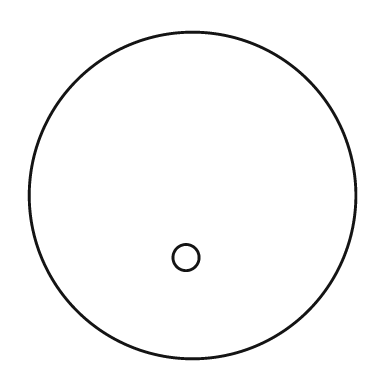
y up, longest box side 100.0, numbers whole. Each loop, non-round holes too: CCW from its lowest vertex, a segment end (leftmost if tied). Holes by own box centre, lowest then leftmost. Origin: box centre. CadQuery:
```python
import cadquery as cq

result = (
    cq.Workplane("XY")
    .moveTo(0.0, 0.0)
    .circle(50.0)
    .moveTo(-2.0, -19.0)
    .circle(4.0)
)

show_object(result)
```